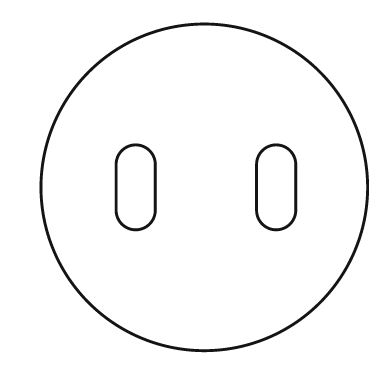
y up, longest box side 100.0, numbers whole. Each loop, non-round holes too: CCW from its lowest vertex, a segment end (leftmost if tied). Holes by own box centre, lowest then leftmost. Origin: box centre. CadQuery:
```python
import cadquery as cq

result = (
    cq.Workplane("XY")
    .moveTo(0.0, 0.0)
    .circle(50.0)
    .moveTo(-27.0, -7.0)
    .threePointArc((-21.0, -13.0), (-15.0, -7.0))
    .lineTo(-15.0, 7.0)
    .threePointArc((-21.0, 13.0), (-27.0, 7.0))
    .close()
    .moveTo(16.0, -7.0)
    .threePointArc((22.0, -13.0), (28.0, -7.0))
    .lineTo(28.0, 7.0)
    .threePointArc((22.0, 13.0), (16.0, 7.0))
    .close()
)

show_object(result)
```